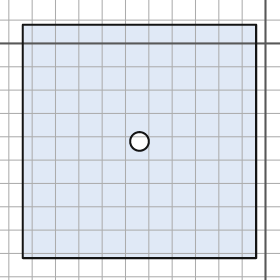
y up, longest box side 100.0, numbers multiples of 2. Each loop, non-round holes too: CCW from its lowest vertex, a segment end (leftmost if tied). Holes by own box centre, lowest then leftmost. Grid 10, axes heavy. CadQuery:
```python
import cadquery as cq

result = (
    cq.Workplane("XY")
    .moveTo(-104.0, -92.0)
    .lineTo(-4.0, -92.0)
    .lineTo(-4.0, 8.0)
    .lineTo(-104.0, 8.0)
    .close()
    .moveTo(-54.0, -42.0)
    .circle(4.0)
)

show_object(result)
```